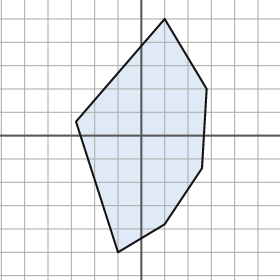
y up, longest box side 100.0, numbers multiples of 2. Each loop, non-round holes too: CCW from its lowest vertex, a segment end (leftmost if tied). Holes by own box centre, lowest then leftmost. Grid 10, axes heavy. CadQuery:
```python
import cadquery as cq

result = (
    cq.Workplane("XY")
    .moveTo(-10.0, -50.0)
    .lineTo(10.0, -38.0)
    .lineTo(26.0, -14.0)
    .lineTo(28.0, 20.0)
    .lineTo(10.0, 50.0)
    .lineTo(-28.0, 6.0)
    .close()
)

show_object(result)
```